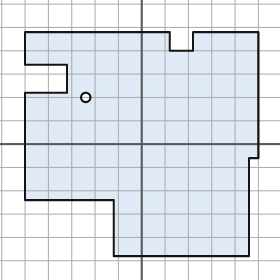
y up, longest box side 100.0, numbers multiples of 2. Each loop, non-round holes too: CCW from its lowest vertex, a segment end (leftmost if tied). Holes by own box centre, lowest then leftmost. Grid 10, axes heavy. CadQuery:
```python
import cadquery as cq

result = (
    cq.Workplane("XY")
    .moveTo(-12.0, -48.0)
    .lineTo(46.0, -48.0)
    .lineTo(46.0, -6.0)
    .lineTo(50.0, -6.0)
    .lineTo(50.0, 48.0)
    .lineTo(22.0, 48.0)
    .lineTo(22.0, 40.0)
    .lineTo(12.0, 40.0)
    .lineTo(12.0, 48.0)
    .lineTo(-50.0, 48.0)
    .lineTo(-50.0, 34.0)
    .lineTo(-32.0, 34.0)
    .lineTo(-32.0, 22.0)
    .lineTo(-50.0, 22.0)
    .lineTo(-50.0, -24.0)
    .lineTo(-12.0, -24.0)
    .close()
    .moveTo(-24.0, 20.0)
    .circle(2.0)
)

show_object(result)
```